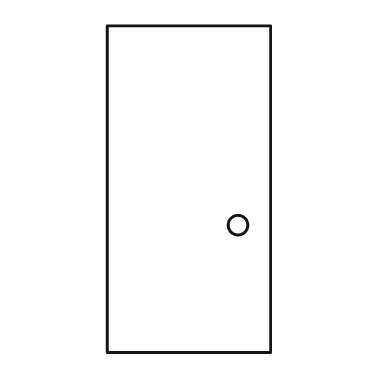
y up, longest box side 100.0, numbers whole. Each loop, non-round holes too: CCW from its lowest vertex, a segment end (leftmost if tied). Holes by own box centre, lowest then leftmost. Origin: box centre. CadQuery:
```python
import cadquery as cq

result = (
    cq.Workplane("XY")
    .moveTo(-25.0, -50.0)
    .lineTo(25.0, -50.0)
    .lineTo(25.0, 50.0)
    .lineTo(-25.0, 50.0)
    .close()
    .moveTo(15.0, -11.0)
    .circle(3.0)
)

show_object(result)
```